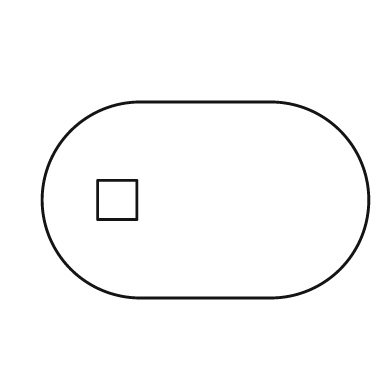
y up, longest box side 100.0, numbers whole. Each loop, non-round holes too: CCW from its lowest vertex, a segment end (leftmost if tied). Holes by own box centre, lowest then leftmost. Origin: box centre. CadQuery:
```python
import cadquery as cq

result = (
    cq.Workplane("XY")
    .moveTo(-20.0, -30.0)
    .lineTo(20.0, -30.0)
    .threePointArc((50.0, 0.0), (20.0, 30.0))
    .lineTo(-20.0, 30.0)
    .threePointArc((-50.0, 0.0), (-20.0, -30.0))
    .close()
    .moveTo(-33.0, -6.0)
    .lineTo(-21.0, -6.0)
    .lineTo(-21.0, 6.0)
    .lineTo(-33.0, 6.0)
    .close()
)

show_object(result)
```